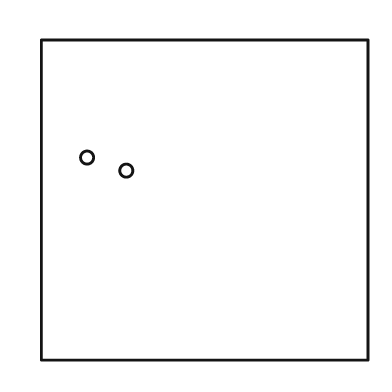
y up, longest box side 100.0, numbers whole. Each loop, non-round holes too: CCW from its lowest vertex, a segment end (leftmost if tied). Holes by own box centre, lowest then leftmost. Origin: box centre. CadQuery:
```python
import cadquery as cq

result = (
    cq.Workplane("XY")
    .moveTo(-50.0, -49.0)
    .lineTo(50.0, -49.0)
    .lineTo(50.0, 49.0)
    .lineTo(-50.0, 49.0)
    .close()
    .moveTo(-24.0, 9.0)
    .circle(2.0)
    .moveTo(-36.0, 13.0)
    .circle(2.0)
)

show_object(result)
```